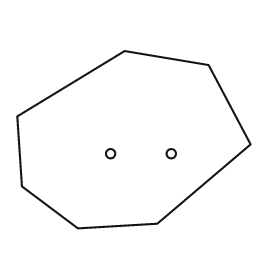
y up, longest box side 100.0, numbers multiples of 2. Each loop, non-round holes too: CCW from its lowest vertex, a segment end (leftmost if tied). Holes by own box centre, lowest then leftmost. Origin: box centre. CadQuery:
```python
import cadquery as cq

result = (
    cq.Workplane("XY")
    .moveTo(-24.0, -38.0)
    .lineTo(10.0, -36.0)
    .lineTo(50.0, -2.0)
    .lineTo(32.0, 32.0)
    .lineTo(-4.0, 38.0)
    .lineTo(-50.0, 10.0)
    .lineTo(-48.0, -20.0)
    .close()
    .moveTo(-10.0, -6.0)
    .circle(2.0)
    .moveTo(16.0, -6.0)
    .circle(2.0)
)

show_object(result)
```